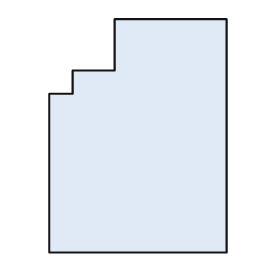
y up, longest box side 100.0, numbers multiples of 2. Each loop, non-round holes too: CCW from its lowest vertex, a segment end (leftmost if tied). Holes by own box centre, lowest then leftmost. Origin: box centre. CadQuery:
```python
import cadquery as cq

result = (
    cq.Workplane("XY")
    .moveTo(-38.0, -50.0)
    .lineTo(38.0, -50.0)
    .lineTo(38.0, 50.0)
    .lineTo(-10.0, 50.0)
    .lineTo(-10.0, 28.0)
    .lineTo(-28.0, 28.0)
    .lineTo(-28.0, 18.0)
    .lineTo(-38.0, 18.0)
    .close()
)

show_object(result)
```